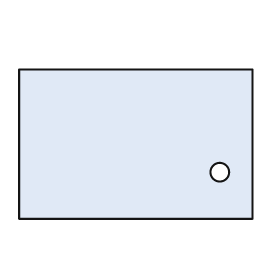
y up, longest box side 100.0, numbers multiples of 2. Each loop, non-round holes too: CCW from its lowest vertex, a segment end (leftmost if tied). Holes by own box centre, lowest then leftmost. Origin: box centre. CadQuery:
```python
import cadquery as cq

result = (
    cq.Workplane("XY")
    .moveTo(-50.0, -32.0)
    .lineTo(50.0, -32.0)
    .lineTo(50.0, 32.0)
    .lineTo(-50.0, 32.0)
    .close()
    .moveTo(36.0, -12.0)
    .circle(4.0)
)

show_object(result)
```